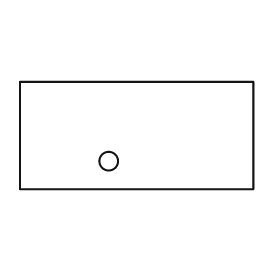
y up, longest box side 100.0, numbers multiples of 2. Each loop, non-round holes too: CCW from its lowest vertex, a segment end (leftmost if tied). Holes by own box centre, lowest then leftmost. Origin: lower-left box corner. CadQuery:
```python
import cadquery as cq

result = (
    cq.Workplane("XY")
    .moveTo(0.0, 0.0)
    .lineTo(100.0, 0.0)
    .lineTo(100.0, 46.0)
    .lineTo(0.0, 46.0)
    .close()
    .moveTo(38.0, 12.0)
    .circle(4.0)
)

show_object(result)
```